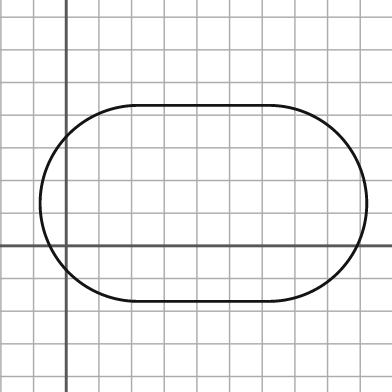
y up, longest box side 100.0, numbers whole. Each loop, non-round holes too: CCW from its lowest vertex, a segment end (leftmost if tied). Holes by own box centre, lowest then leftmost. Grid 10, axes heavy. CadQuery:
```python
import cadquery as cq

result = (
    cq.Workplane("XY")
    .moveTo(22.0, -17.0)
    .lineTo(62.0, -17.0)
    .threePointArc((92.0, 13.0), (62.0, 43.0))
    .lineTo(22.0, 43.0)
    .threePointArc((-8.0, 13.0), (22.0, -17.0))
    .close()
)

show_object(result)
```